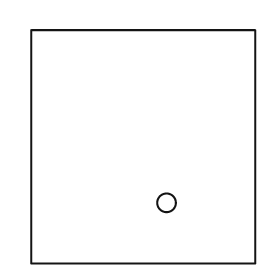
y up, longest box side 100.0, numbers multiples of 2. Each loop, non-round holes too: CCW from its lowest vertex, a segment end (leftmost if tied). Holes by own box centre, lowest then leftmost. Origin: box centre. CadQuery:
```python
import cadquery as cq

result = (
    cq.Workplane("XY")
    .moveTo(-48.0, -50.0)
    .lineTo(48.0, -50.0)
    .lineTo(48.0, 50.0)
    .lineTo(-48.0, 50.0)
    .close()
    .moveTo(10.0, -24.0)
    .circle(4.0)
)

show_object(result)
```